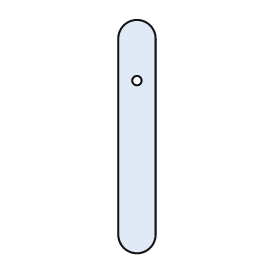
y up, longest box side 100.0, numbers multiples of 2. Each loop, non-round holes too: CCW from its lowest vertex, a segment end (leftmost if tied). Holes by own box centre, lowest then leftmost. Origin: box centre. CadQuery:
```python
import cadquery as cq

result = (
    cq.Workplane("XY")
    .moveTo(-8.0, -42.0)
    .threePointArc((0.0, -50.0), (8.0, -42.0))
    .lineTo(8.0, 42.0)
    .threePointArc((0.0, 50.0), (-8.0, 42.0))
    .close()
    .moveTo(0.0, 24.0)
    .circle(2.0)
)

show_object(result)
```